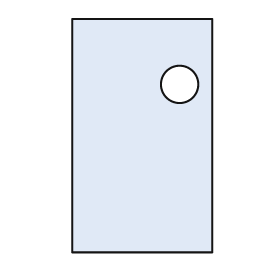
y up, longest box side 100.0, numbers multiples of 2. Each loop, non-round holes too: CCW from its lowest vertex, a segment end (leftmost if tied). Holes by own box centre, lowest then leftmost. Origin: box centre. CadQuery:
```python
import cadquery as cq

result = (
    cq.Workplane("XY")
    .moveTo(-30.0, -50.0)
    .lineTo(30.0, -50.0)
    .lineTo(30.0, 50.0)
    .lineTo(-30.0, 50.0)
    .close()
    .moveTo(16.0, 22.0)
    .circle(8.0)
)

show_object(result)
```